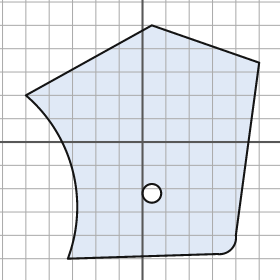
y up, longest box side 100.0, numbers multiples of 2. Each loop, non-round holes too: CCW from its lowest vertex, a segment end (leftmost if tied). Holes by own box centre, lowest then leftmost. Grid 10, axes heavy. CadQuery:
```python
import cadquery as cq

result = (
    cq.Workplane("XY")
    .moveTo(-32.0, -50.0)
    .lineTo(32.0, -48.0)
    .threePointArc((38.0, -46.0), (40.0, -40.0))
    .lineTo(50.0, 34.0)
    .lineTo(4.0, 50.0)
    .lineTo(-50.0, 20.0)
    .threePointArc((-30.0, -12.0), (-32.0, -50.0))
    .close()
    .moveTo(4.0, -22.0)
    .circle(4.0)
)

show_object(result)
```